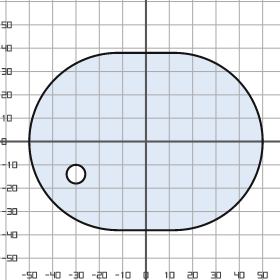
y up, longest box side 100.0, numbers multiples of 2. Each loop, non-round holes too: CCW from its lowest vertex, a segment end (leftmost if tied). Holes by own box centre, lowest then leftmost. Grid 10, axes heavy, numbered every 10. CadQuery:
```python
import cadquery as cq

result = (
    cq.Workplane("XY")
    .moveTo(-12.0, -38.0)
    .lineTo(12.0, -38.0)
    .threePointArc((50.0, 0.0), (12.0, 38.0))
    .lineTo(-12.0, 38.0)
    .threePointArc((-50.0, 0.0), (-12.0, -38.0))
    .close()
    .moveTo(-30.0, -14.0)
    .circle(4.0)
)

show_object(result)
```